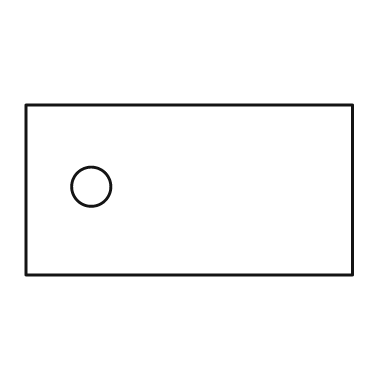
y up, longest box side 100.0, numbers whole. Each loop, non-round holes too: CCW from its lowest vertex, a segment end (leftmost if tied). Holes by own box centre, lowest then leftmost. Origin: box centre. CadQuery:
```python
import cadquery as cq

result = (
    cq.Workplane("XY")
    .moveTo(-50.0, -26.0)
    .lineTo(50.0, -26.0)
    .lineTo(50.0, 26.0)
    .lineTo(-50.0, 26.0)
    .close()
    .moveTo(-30.0, 1.0)
    .circle(6.0)
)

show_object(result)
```